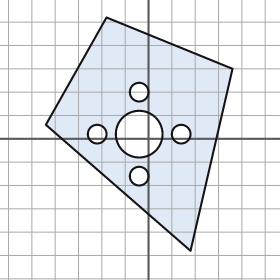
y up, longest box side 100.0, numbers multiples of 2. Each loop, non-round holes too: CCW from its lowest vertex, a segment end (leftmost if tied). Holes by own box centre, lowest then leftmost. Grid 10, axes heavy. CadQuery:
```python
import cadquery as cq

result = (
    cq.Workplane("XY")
    .moveTo(18.0, -48.0)
    .lineTo(36.0, 30.0)
    .lineTo(-18.0, 52.0)
    .lineTo(-44.0, 6.0)
    .close()
    .moveTo(-4.0, -16.0)
    .circle(4.0)
    .moveTo(-22.0, 2.0)
    .circle(4.0)
    .moveTo(-4.0, 2.0)
    .circle(10.0)
    .moveTo(14.0, 2.0)
    .circle(4.0)
    .moveTo(-4.0, 20.0)
    .circle(4.0)
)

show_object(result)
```